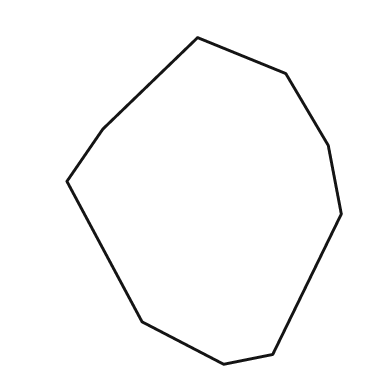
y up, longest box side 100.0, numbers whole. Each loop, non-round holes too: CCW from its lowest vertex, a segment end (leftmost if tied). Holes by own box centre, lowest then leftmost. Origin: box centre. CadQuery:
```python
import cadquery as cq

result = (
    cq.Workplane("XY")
    .moveTo(6.0, -50.0)
    .lineTo(21.0, -47.0)
    .lineTo(42.0, -4.0)
    .lineTo(38.0, 17.0)
    .lineTo(25.0, 39.0)
    .lineTo(-2.0, 50.0)
    .lineTo(-31.0, 22.0)
    .lineTo(-42.0, 6.0)
    .lineTo(-19.0, -37.0)
    .close()
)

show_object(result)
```